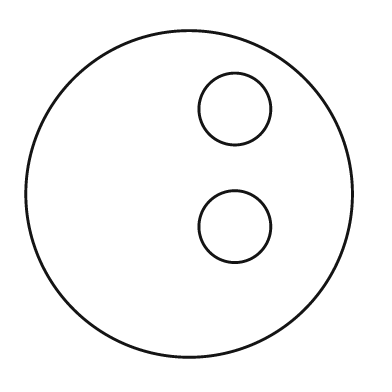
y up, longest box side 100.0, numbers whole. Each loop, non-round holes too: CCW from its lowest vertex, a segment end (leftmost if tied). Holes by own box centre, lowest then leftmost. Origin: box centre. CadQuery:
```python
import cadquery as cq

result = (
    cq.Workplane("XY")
    .moveTo(0.0, 0.0)
    .circle(50.0)
    .moveTo(14.0, -10.0)
    .circle(11.0)
    .moveTo(14.0, 26.0)
    .circle(11.0)
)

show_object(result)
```